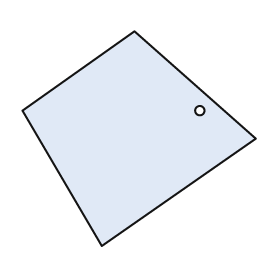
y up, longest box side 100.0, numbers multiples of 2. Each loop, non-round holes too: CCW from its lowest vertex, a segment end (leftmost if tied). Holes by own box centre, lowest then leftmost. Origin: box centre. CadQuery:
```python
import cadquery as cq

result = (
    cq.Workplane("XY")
    .moveTo(-16.0, -46.0)
    .lineTo(50.0, 0.0)
    .lineTo(-2.0, 46.0)
    .lineTo(-50.0, 12.0)
    .close()
    .moveTo(26.0, 12.0)
    .circle(2.0)
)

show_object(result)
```